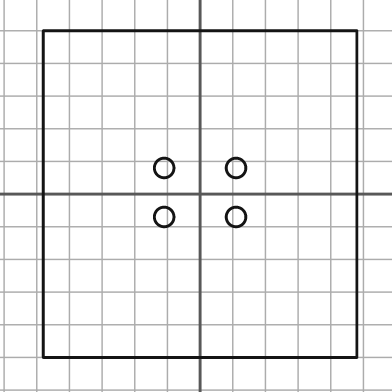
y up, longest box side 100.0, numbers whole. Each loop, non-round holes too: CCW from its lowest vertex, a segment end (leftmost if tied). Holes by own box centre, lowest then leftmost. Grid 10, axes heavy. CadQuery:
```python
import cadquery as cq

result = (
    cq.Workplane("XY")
    .moveTo(-48.0, -50.0)
    .lineTo(48.0, -50.0)
    .lineTo(48.0, 50.0)
    .lineTo(-48.0, 50.0)
    .close()
    .moveTo(-11.0, -7.0)
    .circle(3.0)
    .moveTo(11.0, -7.0)
    .circle(3.0)
    .moveTo(-11.0, 8.0)
    .circle(3.0)
    .moveTo(11.0, 8.0)
    .circle(3.0)
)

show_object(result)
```